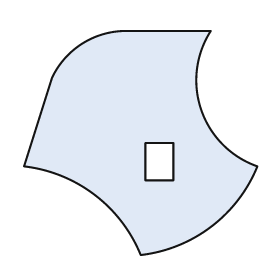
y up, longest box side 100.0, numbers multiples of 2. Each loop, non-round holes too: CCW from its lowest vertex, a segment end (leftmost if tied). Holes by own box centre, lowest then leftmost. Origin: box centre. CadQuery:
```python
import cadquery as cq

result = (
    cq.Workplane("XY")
    .moveTo(0.0, -48.0)
    .threePointArc((30.0, -36.0), (50.0, -10.0))
    .threePointArc((26.0, 14.0), (30.0, 48.0))
    .lineTo(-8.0, 48.0)
    .threePointArc((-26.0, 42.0), (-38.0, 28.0))
    .lineTo(-50.0, -10.0)
    .threePointArc((-20.0, -22.0), (0.0, -48.0))
    .close()
    .moveTo(2.0, -16.0)
    .lineTo(14.0, -16.0)
    .lineTo(14.0, 0.0)
    .lineTo(2.0, 0.0)
    .close()
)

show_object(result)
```